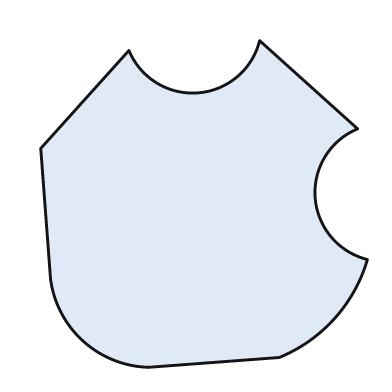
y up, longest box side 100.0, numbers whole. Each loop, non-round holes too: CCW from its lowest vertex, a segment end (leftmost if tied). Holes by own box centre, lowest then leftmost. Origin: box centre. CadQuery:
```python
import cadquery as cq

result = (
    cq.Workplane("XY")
    .moveTo(-17.0, -50.0)
    .lineTo(23.0, -47.0)
    .threePointArc((40.0, -35.0), (50.0, -17.0))
    .threePointArc((34.0, 2.0), (47.0, 23.0))
    .lineTo(17.0, 50.0)
    .threePointArc((-2.0, 34.0), (-23.0, 47.0))
    .lineTo(-50.0, 17.0)
    .lineTo(-47.0, -23.0)
    .threePointArc((-37.0, -42.0), (-17.0, -50.0))
    .close()
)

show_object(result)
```